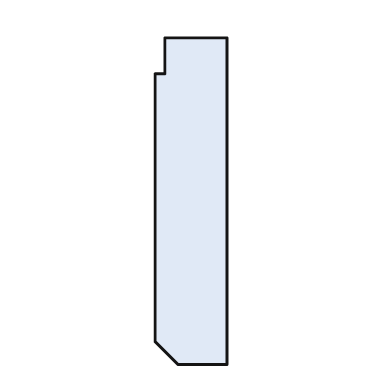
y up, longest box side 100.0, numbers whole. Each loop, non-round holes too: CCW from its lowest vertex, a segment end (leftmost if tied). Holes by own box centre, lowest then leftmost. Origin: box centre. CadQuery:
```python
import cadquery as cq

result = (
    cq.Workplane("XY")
    .moveTo(-4.0, -50.0)
    .lineTo(11.0, -50.0)
    .lineTo(11.0, 50.0)
    .lineTo(-8.0, 50.0)
    .lineTo(-8.0, 39.0)
    .lineTo(-11.0, 39.0)
    .lineTo(-11.0, -43.0)
    .close()
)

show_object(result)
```